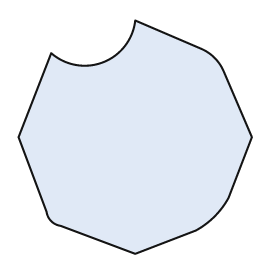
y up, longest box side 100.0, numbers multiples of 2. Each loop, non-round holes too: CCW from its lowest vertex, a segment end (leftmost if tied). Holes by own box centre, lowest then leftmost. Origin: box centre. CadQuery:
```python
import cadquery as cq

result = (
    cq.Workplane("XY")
    .moveTo(0.0, -50.0)
    .lineTo(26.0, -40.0)
    .threePointArc((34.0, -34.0), (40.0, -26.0))
    .lineTo(50.0, 0.0)
    .lineTo(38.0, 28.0)
    .threePointArc((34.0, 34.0), (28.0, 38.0))
    .lineTo(0.0, 50.0)
    .threePointArc((-14.0, 32.0), (-36.0, 36.0))
    .lineTo(-50.0, 0.0)
    .lineTo(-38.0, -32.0)
    .threePointArc((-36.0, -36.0), (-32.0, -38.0))
    .close()
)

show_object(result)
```